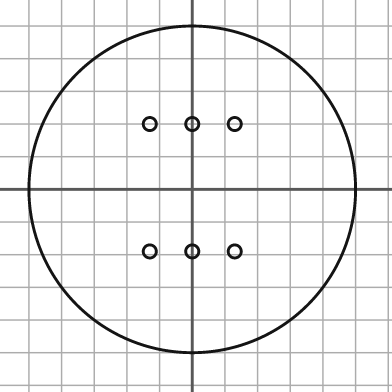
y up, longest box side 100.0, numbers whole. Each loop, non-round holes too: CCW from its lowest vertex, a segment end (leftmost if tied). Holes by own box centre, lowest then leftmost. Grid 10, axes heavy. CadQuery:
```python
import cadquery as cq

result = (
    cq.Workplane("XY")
    .moveTo(0.0, 0.0)
    .circle(50.0)
    .moveTo(-13.0, -19.0)
    .circle(2.0)
    .moveTo(0.0, -19.0)
    .circle(2.0)
    .moveTo(13.0, -19.0)
    .circle(2.0)
    .moveTo(-13.0, 20.0)
    .circle(2.0)
    .moveTo(0.0, 20.0)
    .circle(2.0)
    .moveTo(13.0, 20.0)
    .circle(2.0)
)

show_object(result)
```